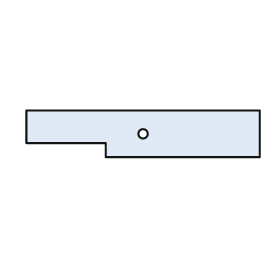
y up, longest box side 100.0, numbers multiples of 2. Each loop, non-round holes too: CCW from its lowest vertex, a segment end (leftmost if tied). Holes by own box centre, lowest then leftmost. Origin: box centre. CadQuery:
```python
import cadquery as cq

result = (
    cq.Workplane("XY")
    .moveTo(-16.0, -10.0)
    .lineTo(50.0, -10.0)
    .lineTo(50.0, 10.0)
    .lineTo(-50.0, 10.0)
    .lineTo(-50.0, -4.0)
    .lineTo(-16.0, -4.0)
    .close()
    .moveTo(0.0, 0.0)
    .circle(2.0)
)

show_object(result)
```